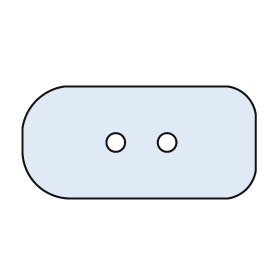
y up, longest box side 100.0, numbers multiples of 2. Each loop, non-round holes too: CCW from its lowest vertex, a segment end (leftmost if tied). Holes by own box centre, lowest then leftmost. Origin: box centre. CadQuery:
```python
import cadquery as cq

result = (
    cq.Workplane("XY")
    .moveTo(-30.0, -24.0)
    .lineTo(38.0, -24.0)
    .threePointArc((46.0, -20.0), (50.0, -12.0))
    .lineTo(50.0, 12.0)
    .threePointArc((46.0, 20.0), (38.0, 24.0))
    .lineTo(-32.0, 24.0)
    .threePointArc((-44.0, 18.0), (-50.0, 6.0))
    .lineTo(-50.0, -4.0)
    .threePointArc((-44.0, -18.0), (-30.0, -24.0))
    .close()
    .moveTo(-10.0, 0.0)
    .circle(4.0)
    .moveTo(12.0, 0.0)
    .circle(4.0)
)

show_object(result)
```